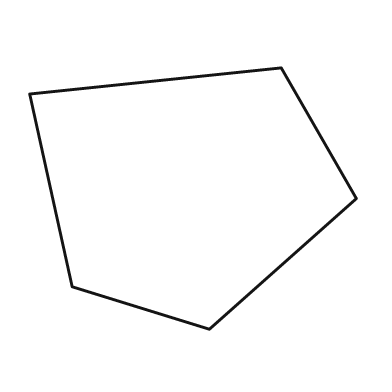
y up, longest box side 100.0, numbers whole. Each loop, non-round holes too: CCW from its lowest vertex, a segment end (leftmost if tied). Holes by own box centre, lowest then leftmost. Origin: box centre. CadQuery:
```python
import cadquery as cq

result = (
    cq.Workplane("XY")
    .moveTo(5.0, -40.0)
    .lineTo(50.0, 0.0)
    .lineTo(27.0, 40.0)
    .lineTo(-50.0, 32.0)
    .lineTo(-37.0, -27.0)
    .close()
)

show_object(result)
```